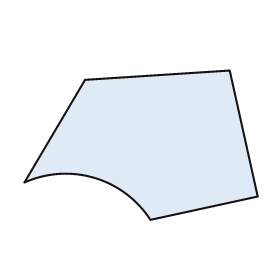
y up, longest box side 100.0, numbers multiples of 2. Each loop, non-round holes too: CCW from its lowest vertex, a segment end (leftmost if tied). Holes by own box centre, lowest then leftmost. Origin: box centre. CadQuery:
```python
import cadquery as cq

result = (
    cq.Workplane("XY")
    .moveTo(4.0, -32.0)
    .lineTo(50.0, -22.0)
    .lineTo(38.0, 32.0)
    .lineTo(-24.0, 28.0)
    .lineTo(-50.0, -16.0)
    .threePointArc((-20.0, -14.0), (4.0, -32.0))
    .close()
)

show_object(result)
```